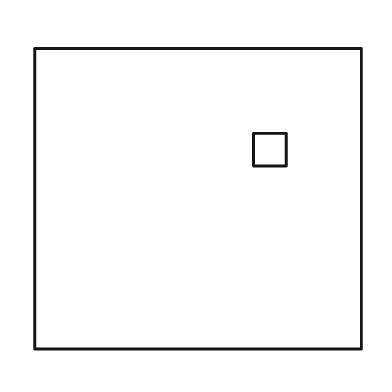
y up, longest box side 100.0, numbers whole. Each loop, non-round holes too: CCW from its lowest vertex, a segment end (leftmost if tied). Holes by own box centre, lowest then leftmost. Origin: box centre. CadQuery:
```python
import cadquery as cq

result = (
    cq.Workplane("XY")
    .moveTo(-50.0, -46.0)
    .lineTo(50.0, -46.0)
    .lineTo(50.0, 46.0)
    .lineTo(-50.0, 46.0)
    .close()
    .moveTo(17.0, 10.0)
    .lineTo(27.0, 10.0)
    .lineTo(27.0, 20.0)
    .lineTo(17.0, 20.0)
    .close()
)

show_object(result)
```